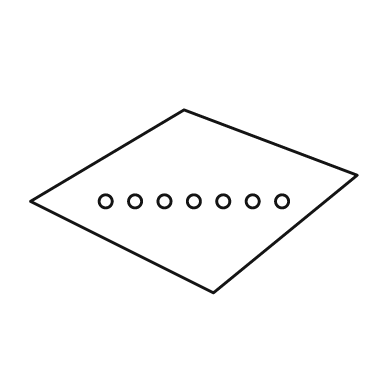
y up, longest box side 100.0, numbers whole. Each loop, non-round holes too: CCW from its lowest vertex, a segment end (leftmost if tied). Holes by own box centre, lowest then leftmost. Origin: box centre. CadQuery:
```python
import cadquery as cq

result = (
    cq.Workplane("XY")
    .moveTo(6.0, -28.0)
    .lineTo(50.0, 8.0)
    .lineTo(-3.0, 28.0)
    .lineTo(-50.0, 0.0)
    .close()
    .moveTo(-27.0, 0.0)
    .circle(2.0)
    .moveTo(-18.0, 0.0)
    .circle(2.0)
    .moveTo(-9.0, 0.0)
    .circle(2.0)
    .moveTo(0.0, 0.0)
    .circle(2.0)
    .moveTo(9.0, 0.0)
    .circle(2.0)
    .moveTo(18.0, 0.0)
    .circle(2.0)
    .moveTo(27.0, 0.0)
    .circle(2.0)
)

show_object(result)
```